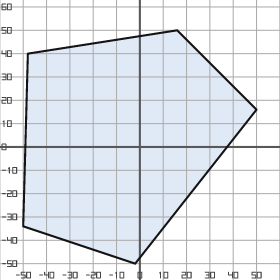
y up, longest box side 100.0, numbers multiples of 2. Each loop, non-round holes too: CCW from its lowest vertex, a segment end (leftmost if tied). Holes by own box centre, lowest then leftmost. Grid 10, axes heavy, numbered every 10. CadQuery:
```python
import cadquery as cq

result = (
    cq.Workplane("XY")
    .moveTo(-2.0, -50.0)
    .lineTo(50.0, 16.0)
    .lineTo(16.0, 50.0)
    .lineTo(-48.0, 40.0)
    .lineTo(-50.0, -34.0)
    .close()
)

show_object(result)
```